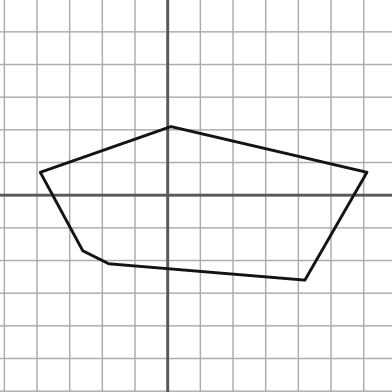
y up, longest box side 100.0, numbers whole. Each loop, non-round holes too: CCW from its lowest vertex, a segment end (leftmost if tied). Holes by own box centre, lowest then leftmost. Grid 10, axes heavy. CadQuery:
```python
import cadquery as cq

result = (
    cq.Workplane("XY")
    .moveTo(42.0, -26.0)
    .lineTo(61.0, 7.0)
    .lineTo(1.0, 21.0)
    .lineTo(-39.0, 7.0)
    .lineTo(-26.0, -17.0)
    .lineTo(-18.0, -21.0)
    .close()
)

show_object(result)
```